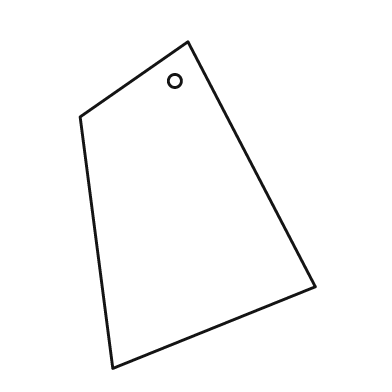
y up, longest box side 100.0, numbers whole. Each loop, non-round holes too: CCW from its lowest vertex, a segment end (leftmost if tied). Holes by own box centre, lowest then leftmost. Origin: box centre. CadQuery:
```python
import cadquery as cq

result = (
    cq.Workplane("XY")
    .moveTo(-26.0, -50.0)
    .lineTo(36.0, -25.0)
    .lineTo(-3.0, 50.0)
    .lineTo(-36.0, 27.0)
    .close()
    .moveTo(-7.0, 38.0)
    .circle(2.0)
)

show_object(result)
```